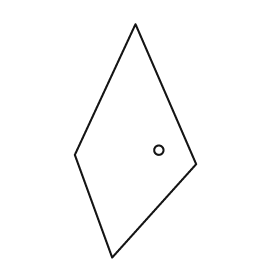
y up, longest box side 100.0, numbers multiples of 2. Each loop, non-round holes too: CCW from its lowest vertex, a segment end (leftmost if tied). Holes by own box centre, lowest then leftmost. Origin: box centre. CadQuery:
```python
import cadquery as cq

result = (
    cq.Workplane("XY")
    .moveTo(-10.0, -50.0)
    .lineTo(26.0, -10.0)
    .lineTo(0.0, 50.0)
    .lineTo(-26.0, -6.0)
    .close()
    .moveTo(10.0, -4.0)
    .circle(2.0)
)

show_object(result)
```